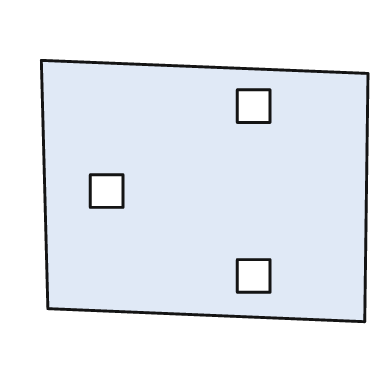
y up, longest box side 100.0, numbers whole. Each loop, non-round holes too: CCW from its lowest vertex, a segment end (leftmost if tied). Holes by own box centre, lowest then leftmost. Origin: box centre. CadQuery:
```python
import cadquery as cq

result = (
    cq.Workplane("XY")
    .moveTo(49.0, -40.0)
    .lineTo(50.0, 36.0)
    .lineTo(-50.0, 40.0)
    .lineTo(-48.0, -36.0)
    .close()
    .moveTo(10.0, -31.0)
    .lineTo(20.0, -31.0)
    .lineTo(20.0, -21.0)
    .lineTo(10.0, -21.0)
    .close()
    .moveTo(-35.0, -5.0)
    .lineTo(-25.0, -5.0)
    .lineTo(-25.0, 5.0)
    .lineTo(-35.0, 5.0)
    .close()
    .moveTo(10.0, 21.0)
    .lineTo(20.0, 21.0)
    .lineTo(20.0, 31.0)
    .lineTo(10.0, 31.0)
    .close()
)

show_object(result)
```